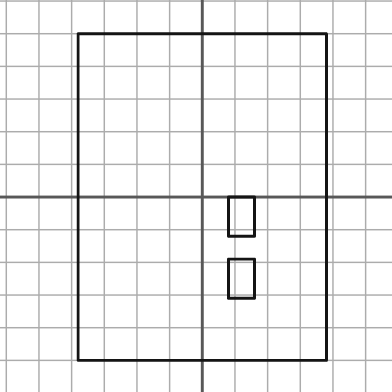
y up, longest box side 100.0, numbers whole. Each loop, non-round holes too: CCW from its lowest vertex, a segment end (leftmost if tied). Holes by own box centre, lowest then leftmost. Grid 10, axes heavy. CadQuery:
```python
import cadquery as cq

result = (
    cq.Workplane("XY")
    .moveTo(-38.0, -50.0)
    .lineTo(38.0, -50.0)
    .lineTo(38.0, 50.0)
    .lineTo(-38.0, 50.0)
    .close()
    .moveTo(8.0, -31.0)
    .lineTo(16.0, -31.0)
    .lineTo(16.0, -19.0)
    .lineTo(8.0, -19.0)
    .close()
    .moveTo(8.0, -12.0)
    .lineTo(16.0, -12.0)
    .lineTo(16.0, 0.0)
    .lineTo(8.0, 0.0)
    .close()
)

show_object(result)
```